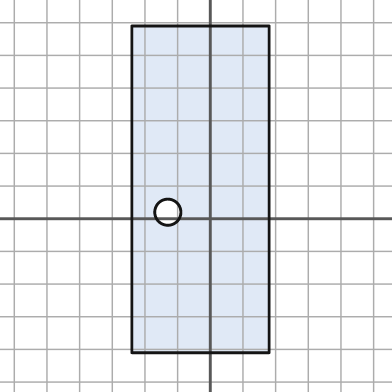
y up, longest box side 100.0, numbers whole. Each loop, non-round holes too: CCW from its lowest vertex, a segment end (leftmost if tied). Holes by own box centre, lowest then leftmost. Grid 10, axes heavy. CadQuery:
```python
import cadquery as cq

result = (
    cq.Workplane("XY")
    .moveTo(-24.0, -41.0)
    .lineTo(18.0, -41.0)
    .lineTo(18.0, 59.0)
    .lineTo(-24.0, 59.0)
    .close()
    .moveTo(-13.0, 2.0)
    .circle(4.0)
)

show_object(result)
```